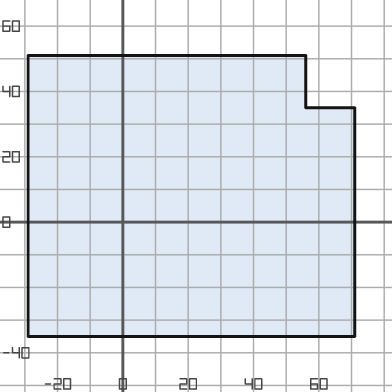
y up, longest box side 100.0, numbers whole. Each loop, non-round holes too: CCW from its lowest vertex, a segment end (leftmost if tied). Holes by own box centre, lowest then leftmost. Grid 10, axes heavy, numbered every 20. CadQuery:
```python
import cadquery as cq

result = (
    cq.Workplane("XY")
    .moveTo(-29.0, -35.0)
    .lineTo(71.0, -35.0)
    .lineTo(71.0, 35.0)
    .lineTo(56.0, 35.0)
    .lineTo(56.0, 51.0)
    .lineTo(-29.0, 51.0)
    .close()
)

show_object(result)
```